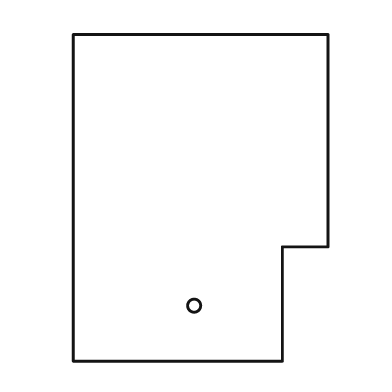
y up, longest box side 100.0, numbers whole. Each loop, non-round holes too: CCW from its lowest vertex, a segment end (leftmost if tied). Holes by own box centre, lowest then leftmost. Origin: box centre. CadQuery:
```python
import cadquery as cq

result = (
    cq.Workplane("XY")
    .moveTo(-39.0, -50.0)
    .lineTo(25.0, -50.0)
    .lineTo(25.0, -15.0)
    .lineTo(39.0, -15.0)
    .lineTo(39.0, 50.0)
    .lineTo(-39.0, 50.0)
    .close()
    .moveTo(-2.0, -33.0)
    .circle(2.0)
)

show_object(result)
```